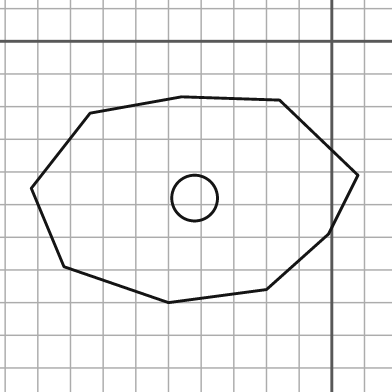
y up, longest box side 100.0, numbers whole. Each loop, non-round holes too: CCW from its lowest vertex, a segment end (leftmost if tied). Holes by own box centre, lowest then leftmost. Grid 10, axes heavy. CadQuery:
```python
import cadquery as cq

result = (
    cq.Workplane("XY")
    .moveTo(-50.0, -80.0)
    .lineTo(-20.0, -76.0)
    .lineTo(-1.0, -59.0)
    .lineTo(8.0, -41.0)
    .lineTo(-16.0, -18.0)
    .lineTo(-46.0, -17.0)
    .lineTo(-74.0, -22.0)
    .lineTo(-92.0, -45.0)
    .lineTo(-82.0, -69.0)
    .close()
    .moveTo(-42.0, -48.0)
    .circle(7.0)
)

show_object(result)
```